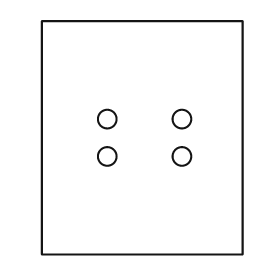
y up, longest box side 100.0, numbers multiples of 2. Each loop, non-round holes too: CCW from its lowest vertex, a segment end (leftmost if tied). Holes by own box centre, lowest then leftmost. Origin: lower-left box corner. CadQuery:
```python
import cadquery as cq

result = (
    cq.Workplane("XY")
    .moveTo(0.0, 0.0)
    .lineTo(86.0, 0.0)
    .lineTo(86.0, 100.0)
    .lineTo(0.0, 100.0)
    .close()
    .moveTo(28.0, 42.0)
    .circle(4.0)
    .moveTo(60.0, 42.0)
    .circle(4.0)
    .moveTo(28.0, 58.0)
    .circle(4.0)
    .moveTo(60.0, 58.0)
    .circle(4.0)
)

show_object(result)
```